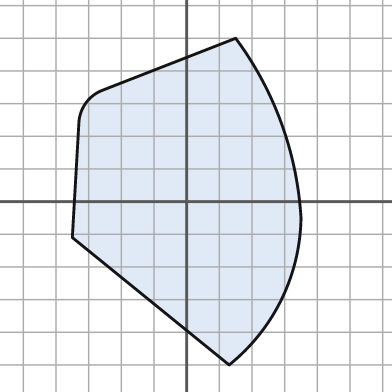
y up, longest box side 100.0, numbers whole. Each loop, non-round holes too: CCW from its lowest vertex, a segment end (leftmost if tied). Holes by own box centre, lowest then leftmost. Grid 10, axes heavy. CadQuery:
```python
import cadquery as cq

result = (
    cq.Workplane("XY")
    .moveTo(13.0, -50.0)
    .threePointArc((29.0, -30.0), (35.0, -5.0))
    .threePointArc((29.0, 24.0), (15.0, 50.0))
    .lineTo(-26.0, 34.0)
    .threePointArc((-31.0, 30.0), (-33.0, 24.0))
    .lineTo(-35.0, -11.0)
    .close()
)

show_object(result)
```